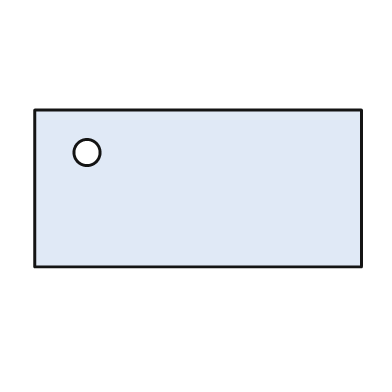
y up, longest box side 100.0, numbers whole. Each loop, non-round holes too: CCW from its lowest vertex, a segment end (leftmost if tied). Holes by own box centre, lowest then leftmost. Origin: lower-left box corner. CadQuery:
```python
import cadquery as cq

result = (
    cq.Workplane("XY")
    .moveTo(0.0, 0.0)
    .lineTo(100.0, 0.0)
    .lineTo(100.0, 48.0)
    .lineTo(0.0, 48.0)
    .close()
    .moveTo(16.0, 35.0)
    .circle(4.0)
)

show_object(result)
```